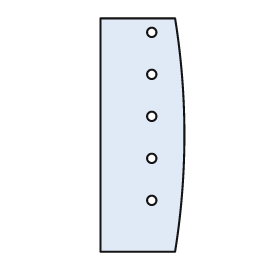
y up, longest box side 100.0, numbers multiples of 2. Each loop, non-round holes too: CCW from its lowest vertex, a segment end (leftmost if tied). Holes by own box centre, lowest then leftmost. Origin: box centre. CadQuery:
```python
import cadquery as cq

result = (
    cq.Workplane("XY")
    .moveTo(-18.0, -50.0)
    .lineTo(14.0, -50.0)
    .threePointArc((18.0, 0.0), (14.0, 50.0))
    .lineTo(-18.0, 50.0)
    .close()
    .moveTo(4.0, -28.0)
    .circle(2.0)
    .moveTo(4.0, -10.0)
    .circle(2.0)
    .moveTo(4.0, 8.0)
    .circle(2.0)
    .moveTo(4.0, 26.0)
    .circle(2.0)
    .moveTo(4.0, 44.0)
    .circle(2.0)
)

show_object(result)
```